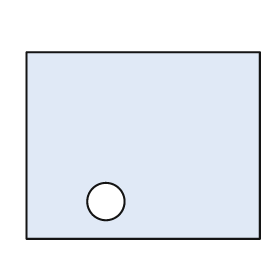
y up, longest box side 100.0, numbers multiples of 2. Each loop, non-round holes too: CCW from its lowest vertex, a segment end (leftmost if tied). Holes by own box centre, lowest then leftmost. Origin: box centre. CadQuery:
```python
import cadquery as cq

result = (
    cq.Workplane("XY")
    .moveTo(-50.0, -40.0)
    .lineTo(50.0, -40.0)
    .lineTo(50.0, 40.0)
    .lineTo(-50.0, 40.0)
    .close()
    .moveTo(-16.0, -24.0)
    .circle(8.0)
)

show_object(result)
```